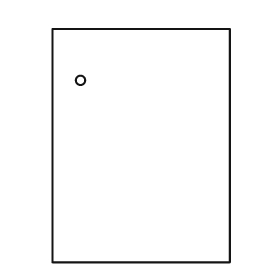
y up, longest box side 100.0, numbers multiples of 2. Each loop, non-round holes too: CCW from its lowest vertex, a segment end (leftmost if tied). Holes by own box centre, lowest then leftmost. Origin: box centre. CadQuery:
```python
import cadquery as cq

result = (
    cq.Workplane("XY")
    .moveTo(-38.0, -50.0)
    .lineTo(38.0, -50.0)
    .lineTo(38.0, 50.0)
    .lineTo(-38.0, 50.0)
    .close()
    .moveTo(-26.0, 28.0)
    .circle(2.0)
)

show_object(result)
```